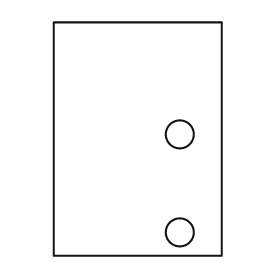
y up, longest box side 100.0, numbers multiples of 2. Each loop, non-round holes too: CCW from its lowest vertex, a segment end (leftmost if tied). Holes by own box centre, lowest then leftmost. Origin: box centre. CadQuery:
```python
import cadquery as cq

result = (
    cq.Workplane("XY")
    .moveTo(-36.0, -50.0)
    .lineTo(36.0, -50.0)
    .lineTo(36.0, 50.0)
    .lineTo(-36.0, 50.0)
    .close()
    .moveTo(18.0, -40.0)
    .circle(6.0)
    .moveTo(18.0, 2.0)
    .circle(6.0)
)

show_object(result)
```